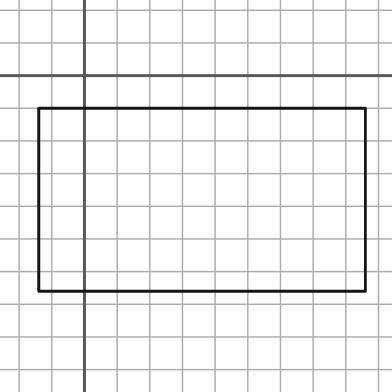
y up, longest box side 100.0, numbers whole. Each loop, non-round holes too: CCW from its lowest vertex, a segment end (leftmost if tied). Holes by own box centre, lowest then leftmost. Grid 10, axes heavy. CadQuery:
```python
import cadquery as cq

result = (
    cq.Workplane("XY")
    .moveTo(-14.0, -66.0)
    .lineTo(86.0, -66.0)
    .lineTo(86.0, -10.0)
    .lineTo(-14.0, -10.0)
    .close()
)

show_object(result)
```